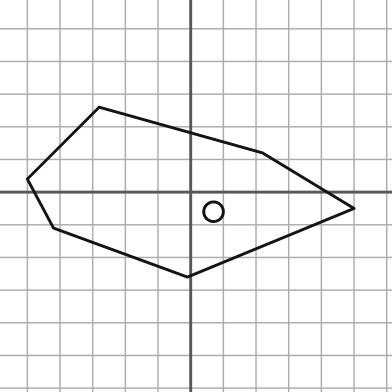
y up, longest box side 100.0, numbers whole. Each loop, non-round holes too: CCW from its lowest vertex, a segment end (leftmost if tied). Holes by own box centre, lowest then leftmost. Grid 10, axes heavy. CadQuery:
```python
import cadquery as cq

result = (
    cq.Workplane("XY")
    .moveTo(-1.0, -26.0)
    .lineTo(50.0, -5.0)
    .lineTo(22.0, 12.0)
    .lineTo(-28.0, 26.0)
    .lineTo(-50.0, 4.0)
    .lineTo(-42.0, -11.0)
    .close()
    .moveTo(7.0, -6.0)
    .circle(3.0)
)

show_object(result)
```